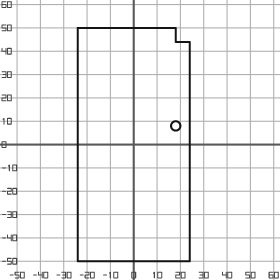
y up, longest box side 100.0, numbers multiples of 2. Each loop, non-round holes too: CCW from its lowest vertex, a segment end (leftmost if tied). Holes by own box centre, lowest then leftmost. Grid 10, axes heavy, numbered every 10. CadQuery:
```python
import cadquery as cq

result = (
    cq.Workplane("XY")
    .moveTo(-24.0, -50.0)
    .lineTo(24.0, -50.0)
    .lineTo(24.0, 44.0)
    .lineTo(18.0, 44.0)
    .lineTo(18.0, 50.0)
    .lineTo(-24.0, 50.0)
    .close()
    .moveTo(18.0, 8.0)
    .circle(2.0)
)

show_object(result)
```